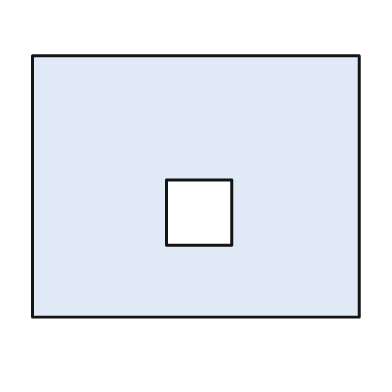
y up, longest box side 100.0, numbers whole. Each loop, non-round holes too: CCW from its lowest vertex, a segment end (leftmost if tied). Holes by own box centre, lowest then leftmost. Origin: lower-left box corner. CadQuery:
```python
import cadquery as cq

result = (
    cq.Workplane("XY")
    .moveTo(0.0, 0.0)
    .lineTo(100.0, 0.0)
    .lineTo(100.0, 80.0)
    .lineTo(0.0, 80.0)
    .close()
    .moveTo(41.0, 22.0)
    .lineTo(61.0, 22.0)
    .lineTo(61.0, 42.0)
    .lineTo(41.0, 42.0)
    .close()
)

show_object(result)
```